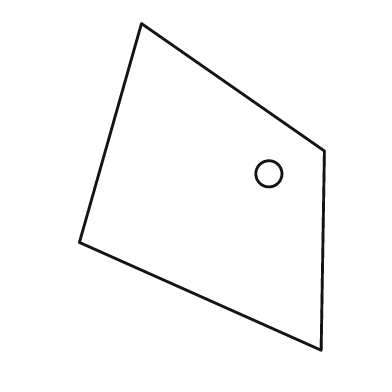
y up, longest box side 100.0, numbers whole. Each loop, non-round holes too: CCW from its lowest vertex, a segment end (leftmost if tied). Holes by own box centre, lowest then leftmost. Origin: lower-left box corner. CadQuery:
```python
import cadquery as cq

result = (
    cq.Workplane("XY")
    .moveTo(74.0, 0.0)
    .lineTo(75.0, 61.0)
    .lineTo(19.0, 100.0)
    .lineTo(0.0, 33.0)
    .close()
    .moveTo(58.0, 54.0)
    .circle(4.0)
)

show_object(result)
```